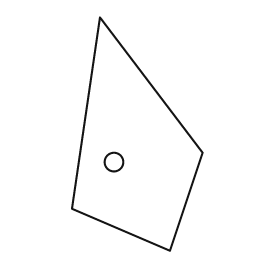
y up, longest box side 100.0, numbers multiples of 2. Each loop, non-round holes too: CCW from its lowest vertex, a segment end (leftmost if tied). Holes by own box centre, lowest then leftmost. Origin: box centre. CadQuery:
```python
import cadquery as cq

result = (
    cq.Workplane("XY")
    .moveTo(14.0, -50.0)
    .lineTo(28.0, -8.0)
    .lineTo(-16.0, 50.0)
    .lineTo(-28.0, -32.0)
    .close()
    .moveTo(-10.0, -12.0)
    .circle(4.0)
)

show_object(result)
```